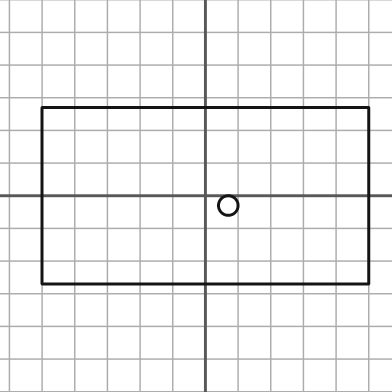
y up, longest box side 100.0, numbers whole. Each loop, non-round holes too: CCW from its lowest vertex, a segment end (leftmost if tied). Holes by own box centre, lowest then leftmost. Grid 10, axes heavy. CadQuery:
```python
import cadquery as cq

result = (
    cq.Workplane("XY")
    .moveTo(-50.0, -27.0)
    .lineTo(50.0, -27.0)
    .lineTo(50.0, 27.0)
    .lineTo(-50.0, 27.0)
    .close()
    .moveTo(7.0, -3.0)
    .circle(3.0)
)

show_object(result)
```